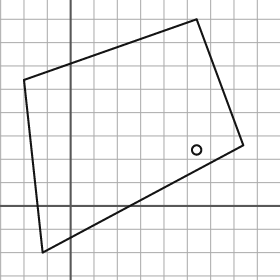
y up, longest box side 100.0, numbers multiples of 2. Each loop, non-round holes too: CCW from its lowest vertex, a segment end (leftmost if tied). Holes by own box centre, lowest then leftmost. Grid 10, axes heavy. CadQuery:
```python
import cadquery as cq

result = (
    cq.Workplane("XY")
    .moveTo(-12.0, -20.0)
    .lineTo(74.0, 26.0)
    .lineTo(54.0, 80.0)
    .lineTo(-20.0, 54.0)
    .close()
    .moveTo(54.0, 24.0)
    .circle(2.0)
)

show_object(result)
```